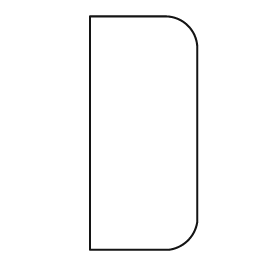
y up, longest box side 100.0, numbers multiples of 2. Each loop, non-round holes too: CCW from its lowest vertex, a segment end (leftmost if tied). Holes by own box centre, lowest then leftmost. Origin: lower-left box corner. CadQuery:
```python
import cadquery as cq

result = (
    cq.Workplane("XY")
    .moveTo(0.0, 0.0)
    .lineTo(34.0, 0.0)
    .threePointArc((42.0, 4.0), (46.0, 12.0))
    .lineTo(46.0, 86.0)
    .threePointArc((42.0, 96.0), (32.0, 100.0))
    .lineTo(0.0, 100.0)
    .close()
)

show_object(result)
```